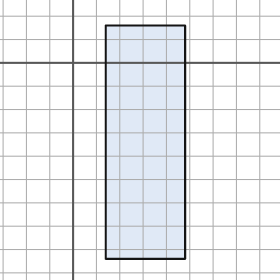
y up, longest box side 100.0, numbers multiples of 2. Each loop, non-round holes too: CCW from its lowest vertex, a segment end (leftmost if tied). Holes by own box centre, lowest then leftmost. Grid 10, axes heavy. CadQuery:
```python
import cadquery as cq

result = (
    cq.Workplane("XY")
    .moveTo(14.0, -84.0)
    .lineTo(48.0, -84.0)
    .lineTo(48.0, 16.0)
    .lineTo(14.0, 16.0)
    .close()
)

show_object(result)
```